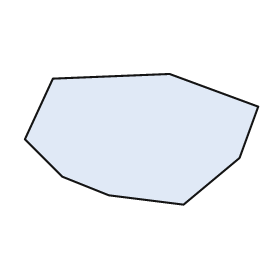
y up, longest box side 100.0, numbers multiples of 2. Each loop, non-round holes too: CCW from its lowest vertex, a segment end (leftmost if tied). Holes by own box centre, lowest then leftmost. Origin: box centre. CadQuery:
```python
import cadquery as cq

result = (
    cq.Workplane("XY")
    .moveTo(18.0, -28.0)
    .lineTo(42.0, -8.0)
    .lineTo(50.0, 14.0)
    .lineTo(12.0, 28.0)
    .lineTo(-38.0, 26.0)
    .lineTo(-50.0, 0.0)
    .lineTo(-34.0, -16.0)
    .lineTo(-14.0, -24.0)
    .close()
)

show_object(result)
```